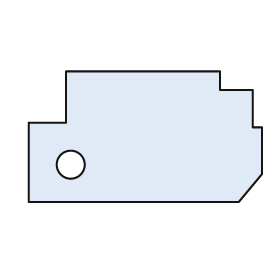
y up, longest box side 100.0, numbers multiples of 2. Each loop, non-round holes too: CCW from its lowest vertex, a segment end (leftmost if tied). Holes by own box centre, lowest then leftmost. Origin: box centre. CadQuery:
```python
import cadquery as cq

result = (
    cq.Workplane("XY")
    .moveTo(-50.0, -28.0)
    .lineTo(40.0, -28.0)
    .lineTo(50.0, -16.0)
    .lineTo(50.0, 4.0)
    .lineTo(46.0, 4.0)
    .lineTo(46.0, 20.0)
    .lineTo(32.0, 20.0)
    .lineTo(32.0, 28.0)
    .lineTo(-34.0, 28.0)
    .lineTo(-34.0, 6.0)
    .lineTo(-50.0, 6.0)
    .close()
    .moveTo(-32.0, -12.0)
    .circle(6.0)
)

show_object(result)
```